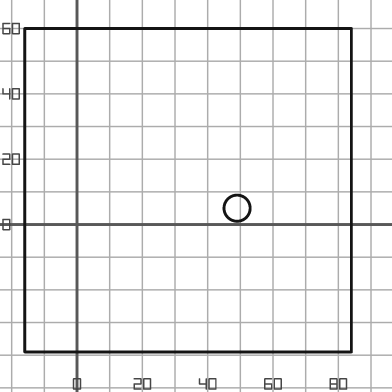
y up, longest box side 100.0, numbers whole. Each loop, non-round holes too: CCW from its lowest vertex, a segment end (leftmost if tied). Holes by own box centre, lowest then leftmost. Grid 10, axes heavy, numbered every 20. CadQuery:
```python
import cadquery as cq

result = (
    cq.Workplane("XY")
    .moveTo(-16.0, -39.0)
    .lineTo(84.0, -39.0)
    .lineTo(84.0, 60.0)
    .lineTo(-16.0, 60.0)
    .close()
    .moveTo(49.0, 5.0)
    .circle(4.0)
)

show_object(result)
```